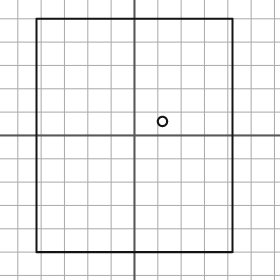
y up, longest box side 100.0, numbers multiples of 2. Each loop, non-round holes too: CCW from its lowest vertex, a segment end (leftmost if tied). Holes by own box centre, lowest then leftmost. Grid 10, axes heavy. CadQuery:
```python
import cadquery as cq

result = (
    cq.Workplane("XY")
    .moveTo(-42.0, -50.0)
    .lineTo(42.0, -50.0)
    .lineTo(42.0, 50.0)
    .lineTo(-42.0, 50.0)
    .close()
    .moveTo(12.0, 6.0)
    .circle(2.0)
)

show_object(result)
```